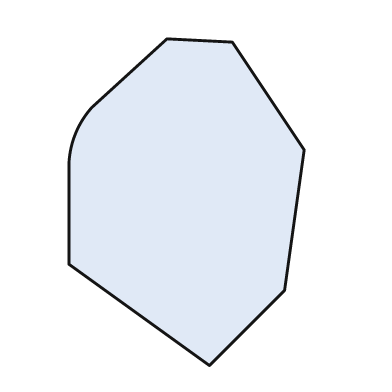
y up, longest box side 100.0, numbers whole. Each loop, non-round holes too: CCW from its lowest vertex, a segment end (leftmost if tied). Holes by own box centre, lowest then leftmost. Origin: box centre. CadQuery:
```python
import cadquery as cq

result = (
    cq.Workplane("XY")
    .moveTo(7.0, -50.0)
    .lineTo(30.0, -27.0)
    .lineTo(36.0, 16.0)
    .lineTo(14.0, 49.0)
    .lineTo(-6.0, 50.0)
    .lineTo(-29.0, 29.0)
    .threePointArc((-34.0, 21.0), (-36.0, 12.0))
    .lineTo(-36.0, -19.0)
    .close()
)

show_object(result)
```